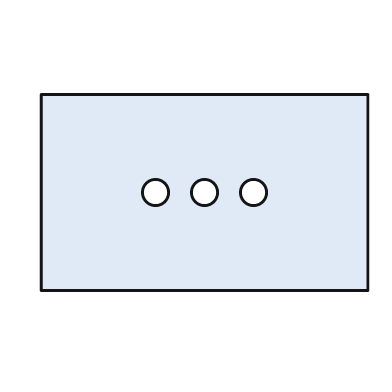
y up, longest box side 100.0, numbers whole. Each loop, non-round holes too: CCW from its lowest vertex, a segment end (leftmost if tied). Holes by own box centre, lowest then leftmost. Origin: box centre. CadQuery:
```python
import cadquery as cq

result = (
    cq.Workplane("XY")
    .moveTo(-50.0, -30.0)
    .lineTo(50.0, -30.0)
    .lineTo(50.0, 30.0)
    .lineTo(-50.0, 30.0)
    .close()
    .moveTo(-15.0, 0.0)
    .circle(4.0)
    .moveTo(0.0, 0.0)
    .circle(4.0)
    .moveTo(15.0, 0.0)
    .circle(4.0)
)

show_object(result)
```